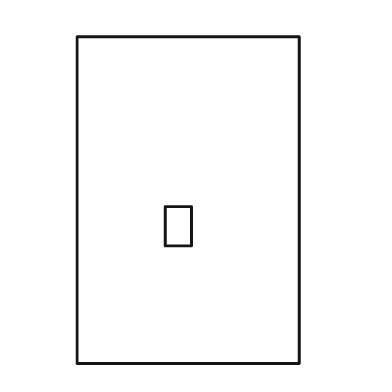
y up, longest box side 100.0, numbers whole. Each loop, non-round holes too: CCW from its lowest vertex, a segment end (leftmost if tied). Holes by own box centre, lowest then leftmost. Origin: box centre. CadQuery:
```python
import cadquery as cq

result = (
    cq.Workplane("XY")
    .moveTo(-34.0, -50.0)
    .lineTo(34.0, -50.0)
    .lineTo(34.0, 50.0)
    .lineTo(-34.0, 50.0)
    .close()
    .moveTo(-7.0, -14.0)
    .lineTo(1.0, -14.0)
    .lineTo(1.0, -2.0)
    .lineTo(-7.0, -2.0)
    .close()
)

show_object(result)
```